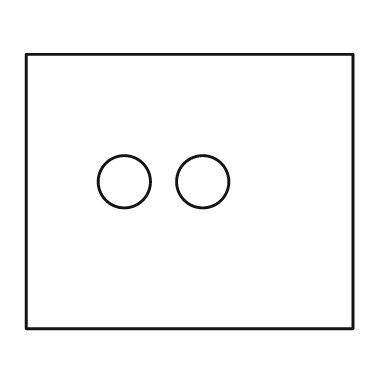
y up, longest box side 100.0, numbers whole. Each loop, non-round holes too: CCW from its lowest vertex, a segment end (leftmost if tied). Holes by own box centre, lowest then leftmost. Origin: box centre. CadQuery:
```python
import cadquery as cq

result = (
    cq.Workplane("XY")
    .moveTo(-50.0, -42.0)
    .lineTo(50.0, -42.0)
    .lineTo(50.0, 42.0)
    .lineTo(-50.0, 42.0)
    .close()
    .moveTo(-20.0, 3.0)
    .circle(8.0)
    .moveTo(4.0, 3.0)
    .circle(8.0)
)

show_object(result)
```